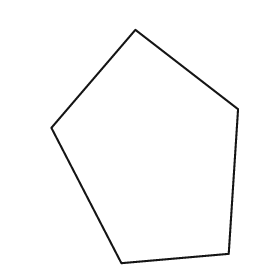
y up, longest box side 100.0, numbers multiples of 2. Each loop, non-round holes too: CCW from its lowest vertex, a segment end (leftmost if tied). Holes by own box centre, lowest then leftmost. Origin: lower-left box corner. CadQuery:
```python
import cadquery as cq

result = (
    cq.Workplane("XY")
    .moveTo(30.0, 0.0)
    .lineTo(76.0, 4.0)
    .lineTo(80.0, 66.0)
    .lineTo(36.0, 100.0)
    .lineTo(0.0, 58.0)
    .close()
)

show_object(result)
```